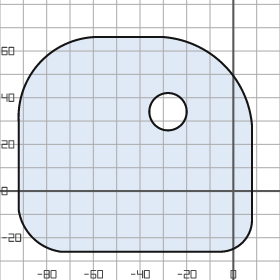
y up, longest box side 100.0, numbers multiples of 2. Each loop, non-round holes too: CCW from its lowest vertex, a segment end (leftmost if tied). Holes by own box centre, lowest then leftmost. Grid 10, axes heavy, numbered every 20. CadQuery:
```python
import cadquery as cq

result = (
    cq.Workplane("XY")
    .moveTo(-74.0, -26.0)
    .lineTo(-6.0, -26.0)
    .threePointArc((4.0, -22.0), (8.0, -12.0))
    .lineTo(8.0, 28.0)
    .threePointArc((-4.0, 54.0), (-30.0, 66.0))
    .lineTo(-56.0, 66.0)
    .threePointArc((-82.0, 56.0), (-92.0, 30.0))
    .lineTo(-92.0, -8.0)
    .threePointArc((-86.0, -20.0), (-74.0, -26.0))
    .close()
    .moveTo(-28.0, 34.0)
    .circle(8.0)
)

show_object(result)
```